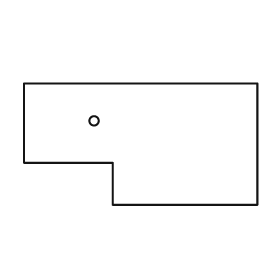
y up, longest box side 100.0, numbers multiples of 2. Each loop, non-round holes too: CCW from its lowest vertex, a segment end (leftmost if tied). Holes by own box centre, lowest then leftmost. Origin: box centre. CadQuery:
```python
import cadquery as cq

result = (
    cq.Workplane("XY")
    .moveTo(-12.0, -26.0)
    .lineTo(50.0, -26.0)
    .lineTo(50.0, 26.0)
    .lineTo(-50.0, 26.0)
    .lineTo(-50.0, -8.0)
    .lineTo(-12.0, -8.0)
    .close()
    .moveTo(-20.0, 10.0)
    .circle(2.0)
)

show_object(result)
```